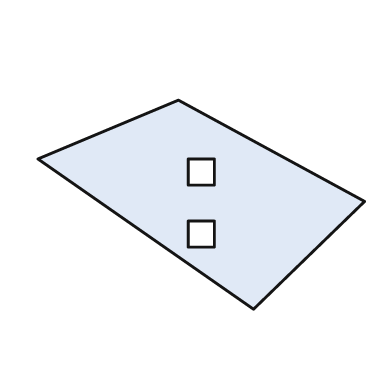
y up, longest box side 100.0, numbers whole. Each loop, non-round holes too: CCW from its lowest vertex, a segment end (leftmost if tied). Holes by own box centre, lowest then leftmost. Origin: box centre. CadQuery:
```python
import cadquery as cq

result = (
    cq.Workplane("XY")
    .moveTo(16.0, -32.0)
    .lineTo(50.0, 1.0)
    .lineTo(-7.0, 32.0)
    .lineTo(-50.0, 14.0)
    .close()
    .moveTo(-4.0, -13.0)
    .lineTo(4.0, -13.0)
    .lineTo(4.0, -5.0)
    .lineTo(-4.0, -5.0)
    .close()
    .moveTo(-4.0, 6.0)
    .lineTo(4.0, 6.0)
    .lineTo(4.0, 14.0)
    .lineTo(-4.0, 14.0)
    .close()
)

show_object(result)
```